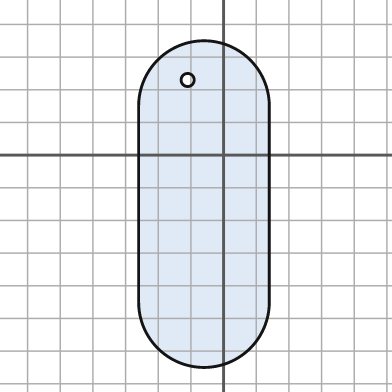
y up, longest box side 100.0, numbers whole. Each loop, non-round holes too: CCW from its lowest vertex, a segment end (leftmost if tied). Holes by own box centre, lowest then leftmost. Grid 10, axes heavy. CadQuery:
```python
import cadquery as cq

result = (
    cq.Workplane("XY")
    .moveTo(-26.0, -45.0)
    .threePointArc((-6.0, -65.0), (14.0, -45.0))
    .lineTo(14.0, 15.0)
    .threePointArc((-6.0, 35.0), (-26.0, 15.0))
    .close()
    .moveTo(-11.0, 23.0)
    .circle(2.0)
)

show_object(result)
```